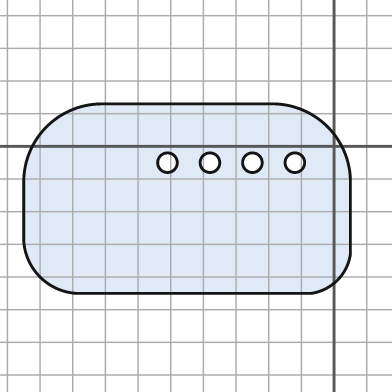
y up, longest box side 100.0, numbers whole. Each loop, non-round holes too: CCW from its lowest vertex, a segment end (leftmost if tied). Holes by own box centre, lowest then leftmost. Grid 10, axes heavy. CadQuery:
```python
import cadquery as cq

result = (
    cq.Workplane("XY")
    .moveTo(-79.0, -45.0)
    .lineTo(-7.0, -45.0)
    .threePointArc((1.0, -41.0), (5.0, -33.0))
    .lineTo(5.0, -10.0)
    .threePointArc((-2.0, 6.0), (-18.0, 13.0))
    .lineTo(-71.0, 13.0)
    .threePointArc((-88.0, 6.0), (-95.0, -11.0))
    .lineTo(-95.0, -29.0)
    .threePointArc((-90.0, -40.0), (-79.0, -45.0))
    .close()
    .moveTo(-51.0, -5.0)
    .circle(3.0)
    .moveTo(-38.0, -5.0)
    .circle(3.0)
    .moveTo(-25.0, -5.0)
    .circle(3.0)
    .moveTo(-12.0, -5.0)
    .circle(3.0)
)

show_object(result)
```